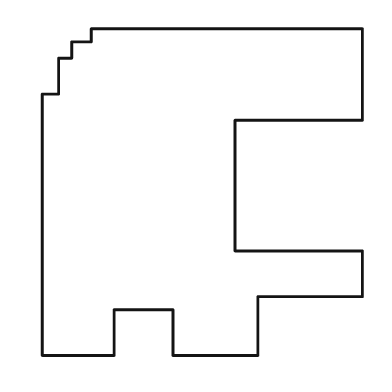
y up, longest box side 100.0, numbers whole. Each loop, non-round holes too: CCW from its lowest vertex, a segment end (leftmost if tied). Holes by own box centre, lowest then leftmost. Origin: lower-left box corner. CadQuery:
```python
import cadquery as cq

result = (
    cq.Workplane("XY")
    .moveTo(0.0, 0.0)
    .lineTo(22.0, 0.0)
    .lineTo(22.0, 14.0)
    .lineTo(40.0, 14.0)
    .lineTo(40.0, 0.0)
    .lineTo(66.0, 0.0)
    .lineTo(66.0, 18.0)
    .lineTo(98.0, 18.0)
    .lineTo(98.0, 32.0)
    .lineTo(59.0, 32.0)
    .lineTo(59.0, 72.0)
    .lineTo(98.0, 72.0)
    .lineTo(98.0, 100.0)
    .lineTo(15.0, 100.0)
    .lineTo(15.0, 96.0)
    .lineTo(9.0, 96.0)
    .lineTo(9.0, 91.0)
    .lineTo(5.0, 91.0)
    .lineTo(5.0, 80.0)
    .lineTo(0.0, 80.0)
    .close()
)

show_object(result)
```